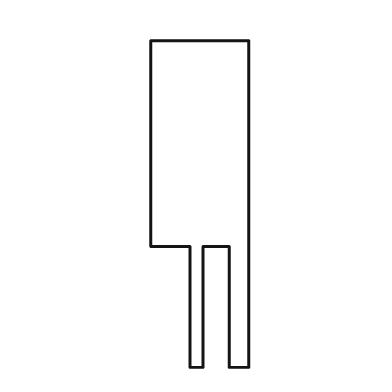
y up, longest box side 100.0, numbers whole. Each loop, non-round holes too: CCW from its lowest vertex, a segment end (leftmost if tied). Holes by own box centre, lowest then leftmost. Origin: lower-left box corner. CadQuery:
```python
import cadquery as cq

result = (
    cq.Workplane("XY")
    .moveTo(12.0, 0.0)
    .lineTo(16.0, 0.0)
    .lineTo(16.0, 37.0)
    .lineTo(24.0, 37.0)
    .lineTo(24.0, 0.0)
    .lineTo(30.0, 0.0)
    .lineTo(30.0, 100.0)
    .lineTo(0.0, 100.0)
    .lineTo(0.0, 37.0)
    .lineTo(12.0, 37.0)
    .close()
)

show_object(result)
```